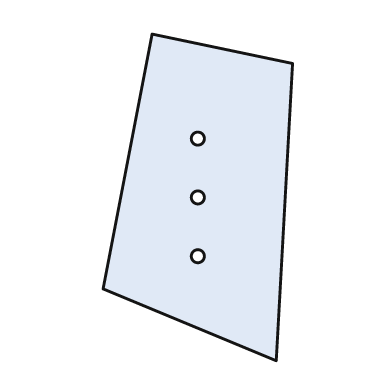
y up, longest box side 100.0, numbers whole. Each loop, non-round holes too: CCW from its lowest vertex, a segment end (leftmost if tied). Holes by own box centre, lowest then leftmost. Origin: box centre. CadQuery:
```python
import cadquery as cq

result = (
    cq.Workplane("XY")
    .moveTo(24.0, -50.0)
    .lineTo(29.0, 41.0)
    .lineTo(-14.0, 50.0)
    .lineTo(-29.0, -28.0)
    .close()
    .moveTo(0.0, -18.0)
    .circle(2.0)
    .moveTo(0.0, 0.0)
    .circle(2.0)
    .moveTo(0.0, 18.0)
    .circle(2.0)
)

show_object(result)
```